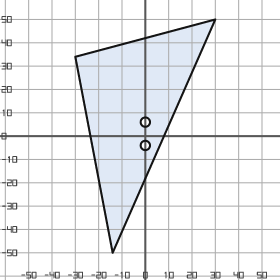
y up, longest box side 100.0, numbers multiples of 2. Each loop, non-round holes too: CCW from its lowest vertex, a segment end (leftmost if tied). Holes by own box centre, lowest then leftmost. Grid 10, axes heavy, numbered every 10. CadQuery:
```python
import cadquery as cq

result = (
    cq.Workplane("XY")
    .moveTo(-14.0, -50.0)
    .lineTo(30.0, 50.0)
    .lineTo(-30.0, 34.0)
    .close()
    .moveTo(0.0, -4.0)
    .circle(2.0)
    .moveTo(0.0, 6.0)
    .circle(2.0)
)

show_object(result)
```